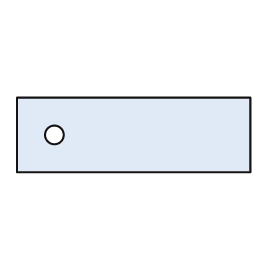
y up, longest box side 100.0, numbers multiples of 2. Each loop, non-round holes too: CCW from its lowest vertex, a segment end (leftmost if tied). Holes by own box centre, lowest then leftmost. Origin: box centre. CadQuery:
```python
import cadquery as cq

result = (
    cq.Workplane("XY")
    .moveTo(-50.0, -16.0)
    .lineTo(50.0, -16.0)
    .lineTo(50.0, 16.0)
    .lineTo(-50.0, 16.0)
    .close()
    .moveTo(-34.0, 0.0)
    .circle(4.0)
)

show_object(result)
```